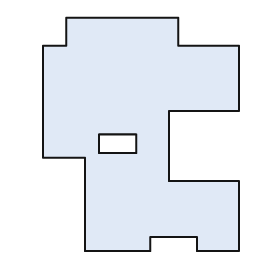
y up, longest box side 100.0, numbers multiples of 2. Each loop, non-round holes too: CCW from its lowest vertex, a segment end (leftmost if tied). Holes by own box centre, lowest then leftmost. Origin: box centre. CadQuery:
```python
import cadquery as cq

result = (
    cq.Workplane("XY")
    .moveTo(-24.0, -50.0)
    .lineTo(4.0, -50.0)
    .lineTo(4.0, -44.0)
    .lineTo(24.0, -44.0)
    .lineTo(24.0, -50.0)
    .lineTo(42.0, -50.0)
    .lineTo(42.0, -20.0)
    .lineTo(12.0, -20.0)
    .lineTo(12.0, 10.0)
    .lineTo(42.0, 10.0)
    .lineTo(42.0, 38.0)
    .lineTo(16.0, 38.0)
    .lineTo(16.0, 50.0)
    .lineTo(-32.0, 50.0)
    .lineTo(-32.0, 38.0)
    .lineTo(-42.0, 38.0)
    .lineTo(-42.0, -10.0)
    .lineTo(-24.0, -10.0)
    .close()
    .moveTo(-18.0, -8.0)
    .lineTo(-2.0, -8.0)
    .lineTo(-2.0, 0.0)
    .lineTo(-18.0, 0.0)
    .close()
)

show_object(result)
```